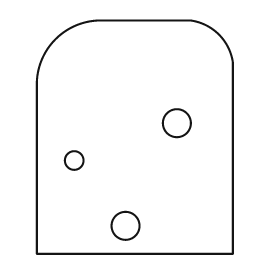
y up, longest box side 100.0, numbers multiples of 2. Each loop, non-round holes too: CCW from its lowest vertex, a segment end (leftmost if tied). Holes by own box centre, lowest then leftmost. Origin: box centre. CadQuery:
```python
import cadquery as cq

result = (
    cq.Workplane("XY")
    .moveTo(-42.0, -50.0)
    .lineTo(42.0, -50.0)
    .lineTo(42.0, 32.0)
    .threePointArc((36.0, 44.0), (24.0, 50.0))
    .lineTo(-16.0, 50.0)
    .threePointArc((-34.0, 42.0), (-42.0, 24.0))
    .close()
    .moveTo(-4.0, -38.0)
    .circle(6.0)
    .moveTo(-26.0, -10.0)
    .circle(4.0)
    .moveTo(18.0, 6.0)
    .circle(6.0)
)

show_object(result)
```